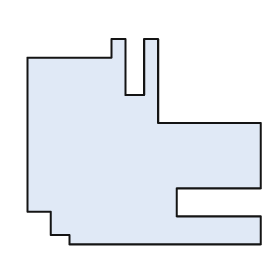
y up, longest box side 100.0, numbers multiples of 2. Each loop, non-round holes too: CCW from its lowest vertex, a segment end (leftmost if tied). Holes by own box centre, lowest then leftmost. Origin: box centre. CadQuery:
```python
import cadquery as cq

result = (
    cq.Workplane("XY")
    .moveTo(-32.0, -44.0)
    .lineTo(50.0, -44.0)
    .lineTo(50.0, -32.0)
    .lineTo(14.0, -32.0)
    .lineTo(14.0, -20.0)
    .lineTo(50.0, -20.0)
    .lineTo(50.0, 8.0)
    .lineTo(6.0, 8.0)
    .lineTo(6.0, 44.0)
    .lineTo(0.0, 44.0)
    .lineTo(0.0, 20.0)
    .lineTo(-8.0, 20.0)
    .lineTo(-8.0, 44.0)
    .lineTo(-14.0, 44.0)
    .lineTo(-14.0, 36.0)
    .lineTo(-50.0, 36.0)
    .lineTo(-50.0, -30.0)
    .lineTo(-40.0, -30.0)
    .lineTo(-40.0, -40.0)
    .lineTo(-32.0, -40.0)
    .close()
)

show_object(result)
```